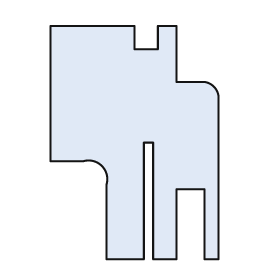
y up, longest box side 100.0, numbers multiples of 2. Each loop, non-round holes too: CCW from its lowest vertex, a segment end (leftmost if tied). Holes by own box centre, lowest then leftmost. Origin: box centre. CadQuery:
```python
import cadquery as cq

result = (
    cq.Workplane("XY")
    .moveTo(-12.0, -50.0)
    .lineTo(4.0, -50.0)
    .lineTo(4.0, 0.0)
    .lineTo(8.0, 0.0)
    .lineTo(8.0, -50.0)
    .lineTo(18.0, -50.0)
    .lineTo(18.0, -20.0)
    .lineTo(30.0, -20.0)
    .lineTo(30.0, -50.0)
    .lineTo(36.0, -50.0)
    .lineTo(36.0, 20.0)
    .threePointArc((34.0, 24.0), (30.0, 26.0))
    .lineTo(18.0, 26.0)
    .lineTo(18.0, 50.0)
    .lineTo(10.0, 50.0)
    .lineTo(10.0, 40.0)
    .lineTo(0.0, 40.0)
    .lineTo(0.0, 50.0)
    .lineTo(-36.0, 50.0)
    .lineTo(-36.0, -8.0)
    .lineTo(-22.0, -8.0)
    .threePointArc((-14.0, -10.0), (-12.0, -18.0))
    .close()
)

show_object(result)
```